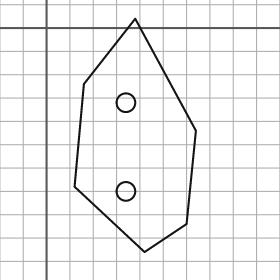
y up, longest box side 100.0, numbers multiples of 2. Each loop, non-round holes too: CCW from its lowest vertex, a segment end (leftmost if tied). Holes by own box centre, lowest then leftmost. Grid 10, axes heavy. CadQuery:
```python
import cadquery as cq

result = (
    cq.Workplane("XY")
    .moveTo(42.0, -96.0)
    .lineTo(60.0, -84.0)
    .lineTo(64.0, -44.0)
    .lineTo(38.0, 4.0)
    .lineTo(16.0, -24.0)
    .lineTo(12.0, -68.0)
    .close()
    .moveTo(34.0, -70.0)
    .circle(4.0)
    .moveTo(34.0, -32.0)
    .circle(4.0)
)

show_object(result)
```